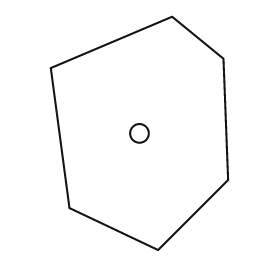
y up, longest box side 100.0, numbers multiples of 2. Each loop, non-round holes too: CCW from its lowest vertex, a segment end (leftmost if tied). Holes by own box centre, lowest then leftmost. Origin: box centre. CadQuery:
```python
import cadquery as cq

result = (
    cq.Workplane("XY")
    .moveTo(8.0, -50.0)
    .lineTo(38.0, -20.0)
    .lineTo(36.0, 32.0)
    .lineTo(14.0, 50.0)
    .lineTo(-38.0, 28.0)
    .lineTo(-30.0, -32.0)
    .close()
    .moveTo(0.0, 0.0)
    .circle(4.0)
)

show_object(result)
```